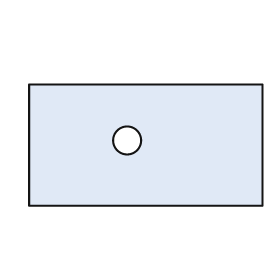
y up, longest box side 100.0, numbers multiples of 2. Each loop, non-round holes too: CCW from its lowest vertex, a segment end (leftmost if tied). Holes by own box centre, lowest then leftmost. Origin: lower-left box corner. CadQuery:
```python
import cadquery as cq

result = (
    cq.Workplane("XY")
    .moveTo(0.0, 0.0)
    .lineTo(100.0, 0.0)
    .lineTo(100.0, 52.0)
    .lineTo(0.0, 52.0)
    .close()
    .moveTo(42.0, 28.0)
    .circle(6.0)
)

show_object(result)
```